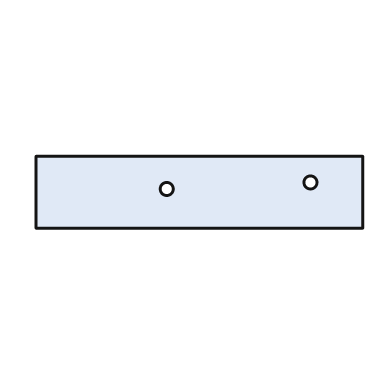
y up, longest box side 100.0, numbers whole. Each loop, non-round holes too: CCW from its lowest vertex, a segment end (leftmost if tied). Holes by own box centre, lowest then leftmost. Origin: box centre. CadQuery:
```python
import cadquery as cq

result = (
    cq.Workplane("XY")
    .moveTo(-50.0, -11.0)
    .lineTo(50.0, -11.0)
    .lineTo(50.0, 11.0)
    .lineTo(-50.0, 11.0)
    .close()
    .moveTo(-10.0, 1.0)
    .circle(2.0)
    .moveTo(34.0, 3.0)
    .circle(2.0)
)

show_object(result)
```